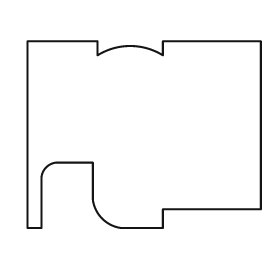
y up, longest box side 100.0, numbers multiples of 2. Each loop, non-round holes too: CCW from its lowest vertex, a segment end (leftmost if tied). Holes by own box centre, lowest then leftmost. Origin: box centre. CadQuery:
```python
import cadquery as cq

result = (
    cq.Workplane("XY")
    .moveTo(-50.0, -40.0)
    .lineTo(-44.0, -40.0)
    .lineTo(-44.0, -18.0)
    .threePointArc((-42.0, -14.0), (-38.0, -12.0))
    .lineTo(-22.0, -12.0)
    .lineTo(-22.0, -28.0)
    .threePointArc((-18.0, -36.0), (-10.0, -40.0))
    .lineTo(8.0, -40.0)
    .lineTo(8.0, -32.0)
    .lineTo(50.0, -32.0)
    .lineTo(50.0, 40.0)
    .lineTo(8.0, 40.0)
    .lineTo(8.0, 34.0)
    .threePointArc((-6.0, 38.0), (-20.0, 34.0))
    .lineTo(-20.0, 40.0)
    .lineTo(-50.0, 40.0)
    .close()
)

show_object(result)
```